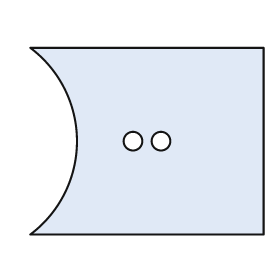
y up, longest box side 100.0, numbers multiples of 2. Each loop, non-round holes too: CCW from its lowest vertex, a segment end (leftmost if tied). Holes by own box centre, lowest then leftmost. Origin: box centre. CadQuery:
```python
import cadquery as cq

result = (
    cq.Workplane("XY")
    .moveTo(-50.0, -40.0)
    .lineTo(50.0, -40.0)
    .lineTo(50.0, 40.0)
    .lineTo(-50.0, 40.0)
    .threePointArc((-30.0, 0.0), (-50.0, -40.0))
    .close()
    .moveTo(-6.0, 0.0)
    .circle(4.0)
    .moveTo(6.0, 0.0)
    .circle(4.0)
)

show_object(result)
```